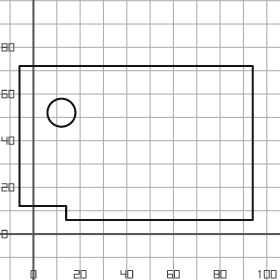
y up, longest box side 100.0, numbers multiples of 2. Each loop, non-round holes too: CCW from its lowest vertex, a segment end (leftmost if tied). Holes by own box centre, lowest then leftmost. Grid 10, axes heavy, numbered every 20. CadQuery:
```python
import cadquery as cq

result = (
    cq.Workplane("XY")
    .moveTo(14.0, 6.0)
    .lineTo(94.0, 6.0)
    .lineTo(94.0, 72.0)
    .lineTo(-6.0, 72.0)
    .lineTo(-6.0, 12.0)
    .lineTo(14.0, 12.0)
    .close()
    .moveTo(12.0, 52.0)
    .circle(6.0)
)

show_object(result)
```